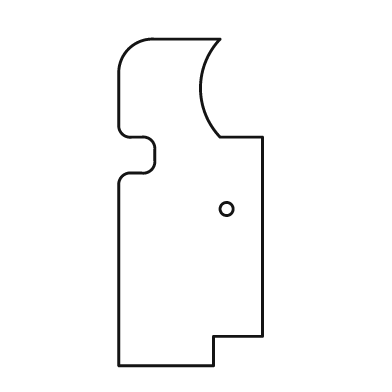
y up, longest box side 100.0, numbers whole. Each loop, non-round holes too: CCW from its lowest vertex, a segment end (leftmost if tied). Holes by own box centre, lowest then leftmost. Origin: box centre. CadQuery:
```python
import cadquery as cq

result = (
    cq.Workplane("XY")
    .moveTo(-22.0, -50.0)
    .lineTo(7.0, -50.0)
    .lineTo(7.0, -41.0)
    .lineTo(22.0, -41.0)
    .lineTo(22.0, 20.0)
    .lineTo(9.0, 20.0)
    .threePointArc((3.0, 35.0), (9.0, 50.0))
    .lineTo(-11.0, 50.0)
    .threePointArc((-19.0, 47.0), (-22.0, 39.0))
    .lineTo(-22.0, 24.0)
    .threePointArc((-21.0, 21.0), (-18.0, 20.0))
    .lineTo(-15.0, 20.0)
    .threePointArc((-12.0, 19.0), (-11.0, 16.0))
    .lineTo(-11.0, 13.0)
    .threePointArc((-12.0, 10.0), (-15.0, 9.0))
    .lineTo(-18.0, 9.0)
    .threePointArc((-21.0, 8.0), (-22.0, 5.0))
    .close()
    .moveTo(11.0, -2.0)
    .circle(2.0)
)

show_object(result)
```